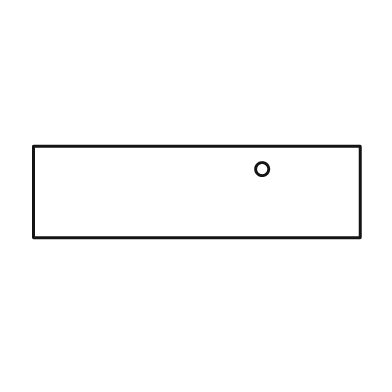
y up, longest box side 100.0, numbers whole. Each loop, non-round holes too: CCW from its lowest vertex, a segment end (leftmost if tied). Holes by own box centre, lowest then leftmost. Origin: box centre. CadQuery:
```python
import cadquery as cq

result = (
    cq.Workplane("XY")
    .moveTo(-50.0, -14.0)
    .lineTo(50.0, -14.0)
    .lineTo(50.0, 14.0)
    .lineTo(-50.0, 14.0)
    .close()
    .moveTo(20.0, 7.0)
    .circle(2.0)
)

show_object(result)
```